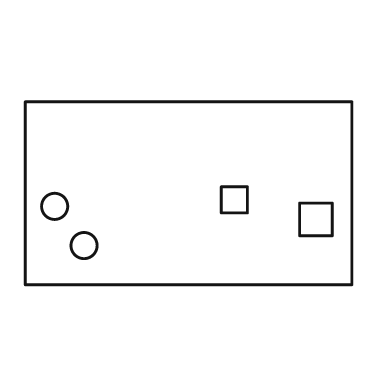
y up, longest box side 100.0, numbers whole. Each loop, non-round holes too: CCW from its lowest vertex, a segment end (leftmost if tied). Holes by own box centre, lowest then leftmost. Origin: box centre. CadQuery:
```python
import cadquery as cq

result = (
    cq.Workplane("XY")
    .moveTo(-50.0, -28.0)
    .lineTo(50.0, -28.0)
    .lineTo(50.0, 28.0)
    .lineTo(-50.0, 28.0)
    .close()
    .moveTo(-32.0, -16.0)
    .circle(4.0)
    .moveTo(34.0, -13.0)
    .lineTo(44.0, -13.0)
    .lineTo(44.0, -3.0)
    .lineTo(34.0, -3.0)
    .close()
    .moveTo(-41.0, -4.0)
    .circle(4.0)
    .moveTo(10.0, -6.0)
    .lineTo(18.0, -6.0)
    .lineTo(18.0, 2.0)
    .lineTo(10.0, 2.0)
    .close()
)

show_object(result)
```